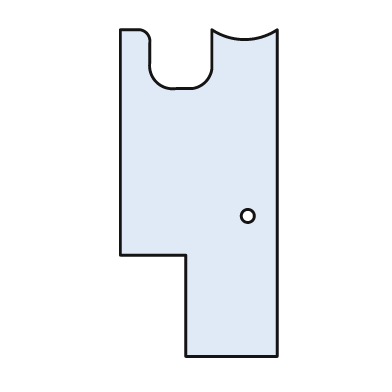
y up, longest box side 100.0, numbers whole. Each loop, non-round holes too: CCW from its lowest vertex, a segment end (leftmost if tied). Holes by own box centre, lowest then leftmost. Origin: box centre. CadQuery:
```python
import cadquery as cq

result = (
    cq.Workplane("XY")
    .moveTo(-4.0, -50.0)
    .lineTo(24.0, -50.0)
    .lineTo(24.0, 50.0)
    .threePointArc((14.0, 47.0), (4.0, 50.0))
    .lineTo(4.0, 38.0)
    .threePointArc((2.0, 34.0), (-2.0, 32.0))
    .lineTo(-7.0, 32.0)
    .threePointArc((-13.0, 34.0), (-15.0, 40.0))
    .lineTo(-15.0, 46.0)
    .threePointArc((-16.0, 49.0), (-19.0, 50.0))
    .lineTo(-24.0, 50.0)
    .lineTo(-24.0, -19.0)
    .lineTo(-4.0, -19.0)
    .close()
    .moveTo(15.0, -7.0)
    .circle(2.0)
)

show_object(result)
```